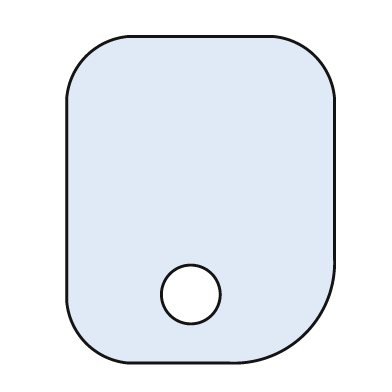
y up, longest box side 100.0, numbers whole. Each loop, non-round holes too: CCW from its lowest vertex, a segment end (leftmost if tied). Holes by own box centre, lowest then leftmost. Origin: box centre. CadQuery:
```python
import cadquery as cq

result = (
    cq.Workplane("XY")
    .moveTo(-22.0, -50.0)
    .lineTo(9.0, -50.0)
    .threePointArc((32.0, -41.0), (41.0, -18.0))
    .lineTo(41.0, 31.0)
    .threePointArc((35.0, 44.0), (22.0, 50.0))
    .lineTo(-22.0, 50.0)
    .threePointArc((-35.0, 44.0), (-41.0, 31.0))
    .lineTo(-41.0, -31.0)
    .threePointArc((-35.0, -44.0), (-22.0, -50.0))
    .close()
    .moveTo(-3.0, -29.0)
    .circle(9.0)
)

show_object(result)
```